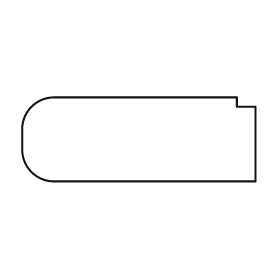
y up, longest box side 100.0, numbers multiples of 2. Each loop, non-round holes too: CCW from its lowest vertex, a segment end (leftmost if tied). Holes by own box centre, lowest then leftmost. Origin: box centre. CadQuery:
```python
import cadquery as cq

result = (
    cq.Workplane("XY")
    .moveTo(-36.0, -18.0)
    .lineTo(50.0, -18.0)
    .lineTo(50.0, 14.0)
    .lineTo(42.0, 14.0)
    .lineTo(42.0, 18.0)
    .lineTo(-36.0, 18.0)
    .threePointArc((-46.0, 14.0), (-50.0, 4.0))
    .lineTo(-50.0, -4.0)
    .threePointArc((-46.0, -14.0), (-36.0, -18.0))
    .close()
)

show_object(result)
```